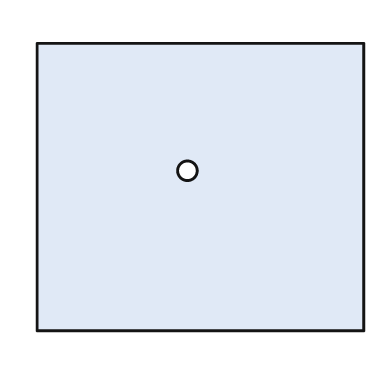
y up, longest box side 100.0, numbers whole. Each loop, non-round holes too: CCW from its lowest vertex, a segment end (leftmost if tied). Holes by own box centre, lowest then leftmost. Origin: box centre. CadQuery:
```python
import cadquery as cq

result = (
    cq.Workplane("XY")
    .moveTo(-50.0, -44.0)
    .lineTo(50.0, -44.0)
    .lineTo(50.0, 44.0)
    .lineTo(-50.0, 44.0)
    .close()
    .moveTo(-4.0, 5.0)
    .circle(3.0)
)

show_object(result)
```